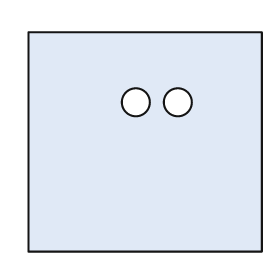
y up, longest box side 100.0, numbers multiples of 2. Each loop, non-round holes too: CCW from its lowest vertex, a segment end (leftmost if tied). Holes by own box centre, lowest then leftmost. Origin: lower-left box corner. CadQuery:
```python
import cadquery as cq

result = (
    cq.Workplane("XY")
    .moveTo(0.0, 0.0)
    .lineTo(100.0, 0.0)
    .lineTo(100.0, 94.0)
    .lineTo(0.0, 94.0)
    .close()
    .moveTo(46.0, 64.0)
    .circle(6.0)
    .moveTo(64.0, 64.0)
    .circle(6.0)
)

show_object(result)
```